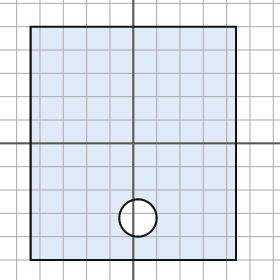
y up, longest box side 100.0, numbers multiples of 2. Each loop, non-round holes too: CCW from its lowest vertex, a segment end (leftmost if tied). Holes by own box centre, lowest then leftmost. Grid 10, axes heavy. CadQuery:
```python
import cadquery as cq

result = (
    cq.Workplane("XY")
    .moveTo(-44.0, -50.0)
    .lineTo(44.0, -50.0)
    .lineTo(44.0, 50.0)
    .lineTo(-44.0, 50.0)
    .close()
    .moveTo(2.0, -32.0)
    .circle(8.0)
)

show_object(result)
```